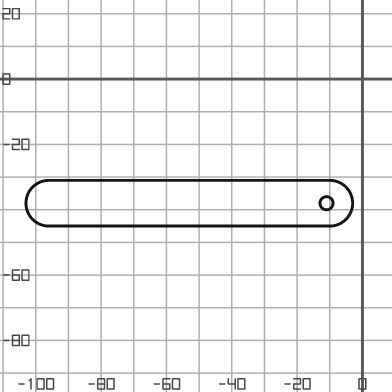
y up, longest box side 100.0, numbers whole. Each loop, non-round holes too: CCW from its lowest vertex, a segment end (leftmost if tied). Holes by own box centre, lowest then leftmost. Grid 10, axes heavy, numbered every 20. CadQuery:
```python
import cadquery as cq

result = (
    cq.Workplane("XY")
    .moveTo(-96.0, -45.0)
    .lineTo(-10.0, -45.0)
    .threePointArc((-3.0, -38.0), (-10.0, -31.0))
    .lineTo(-96.0, -31.0)
    .threePointArc((-103.0, -38.0), (-96.0, -45.0))
    .close()
    .moveTo(-11.0, -38.0)
    .circle(2.0)
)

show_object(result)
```